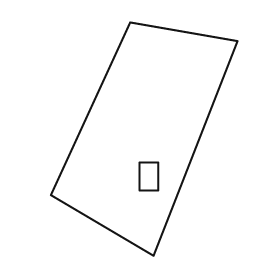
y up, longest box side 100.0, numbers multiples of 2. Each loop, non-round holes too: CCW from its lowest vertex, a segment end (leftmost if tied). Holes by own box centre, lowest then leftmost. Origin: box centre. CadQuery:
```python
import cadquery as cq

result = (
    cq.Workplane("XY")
    .moveTo(4.0, -50.0)
    .lineTo(40.0, 42.0)
    .lineTo(-6.0, 50.0)
    .lineTo(-40.0, -24.0)
    .close()
    .moveTo(-2.0, -22.0)
    .lineTo(6.0, -22.0)
    .lineTo(6.0, -10.0)
    .lineTo(-2.0, -10.0)
    .close()
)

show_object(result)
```